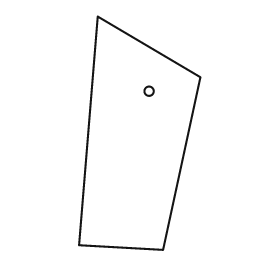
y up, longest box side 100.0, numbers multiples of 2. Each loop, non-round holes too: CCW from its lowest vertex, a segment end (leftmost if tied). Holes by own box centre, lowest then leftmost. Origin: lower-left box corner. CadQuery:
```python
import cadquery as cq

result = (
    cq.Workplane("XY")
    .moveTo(36.0, 0.0)
    .lineTo(52.0, 74.0)
    .lineTo(8.0, 100.0)
    .lineTo(0.0, 2.0)
    .close()
    .moveTo(30.0, 68.0)
    .circle(2.0)
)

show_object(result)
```